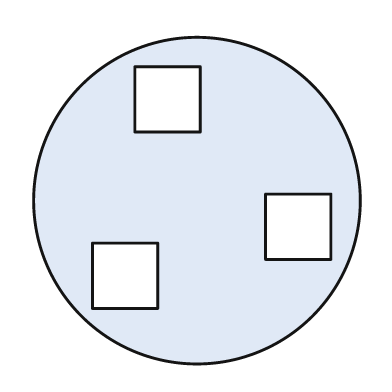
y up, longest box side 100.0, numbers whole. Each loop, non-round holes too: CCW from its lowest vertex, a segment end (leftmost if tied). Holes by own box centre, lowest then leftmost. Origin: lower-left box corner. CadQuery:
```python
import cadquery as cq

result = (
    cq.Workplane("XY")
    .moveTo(50.0, 50.0)
    .circle(50.0)
    .moveTo(18.0, 17.0)
    .lineTo(38.0, 17.0)
    .lineTo(38.0, 37.0)
    .lineTo(18.0, 37.0)
    .close()
    .moveTo(71.0, 32.0)
    .lineTo(91.0, 32.0)
    .lineTo(91.0, 52.0)
    .lineTo(71.0, 52.0)
    .close()
    .moveTo(31.0, 71.0)
    .lineTo(51.0, 71.0)
    .lineTo(51.0, 91.0)
    .lineTo(31.0, 91.0)
    .close()
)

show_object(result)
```